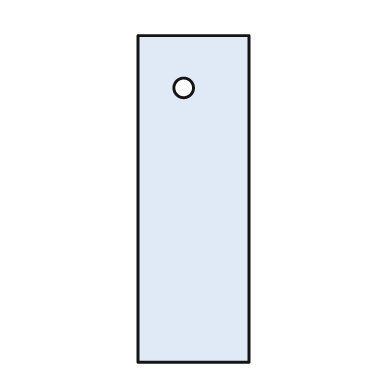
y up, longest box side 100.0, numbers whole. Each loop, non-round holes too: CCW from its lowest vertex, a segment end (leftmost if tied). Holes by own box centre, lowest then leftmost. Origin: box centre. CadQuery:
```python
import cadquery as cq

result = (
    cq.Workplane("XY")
    .moveTo(-17.0, -50.0)
    .lineTo(17.0, -50.0)
    .lineTo(17.0, 50.0)
    .lineTo(-17.0, 50.0)
    .close()
    .moveTo(-3.0, 34.0)
    .circle(3.0)
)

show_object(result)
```